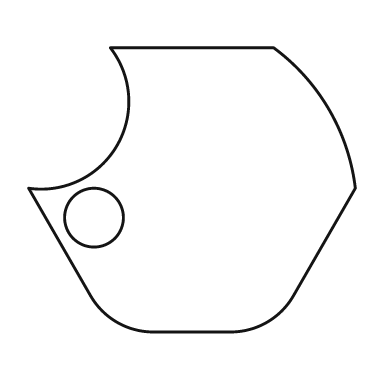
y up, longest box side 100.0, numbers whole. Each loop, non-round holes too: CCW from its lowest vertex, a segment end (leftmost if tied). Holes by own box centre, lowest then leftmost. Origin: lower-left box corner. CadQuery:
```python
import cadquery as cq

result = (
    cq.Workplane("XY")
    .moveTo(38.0, 0.0)
    .lineTo(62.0, 0.0)
    .threePointArc((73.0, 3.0), (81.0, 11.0))
    .lineTo(100.0, 44.0)
    .threePointArc((92.0, 68.0), (75.0, 87.0))
    .lineTo(25.0, 87.0)
    .threePointArc((27.0, 57.0), (0.0, 44.0))
    .lineTo(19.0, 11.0)
    .threePointArc((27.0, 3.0), (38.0, 0.0))
    .close()
    .moveTo(20.0, 35.0)
    .circle(9.0)
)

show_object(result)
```